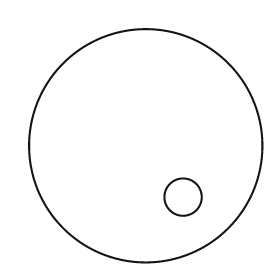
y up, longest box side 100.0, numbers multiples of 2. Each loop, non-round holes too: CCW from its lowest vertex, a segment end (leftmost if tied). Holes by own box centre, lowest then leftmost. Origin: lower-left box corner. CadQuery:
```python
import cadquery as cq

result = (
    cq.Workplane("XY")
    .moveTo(50.0, 50.0)
    .circle(50.0)
    .moveTo(66.0, 28.0)
    .circle(8.0)
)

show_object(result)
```